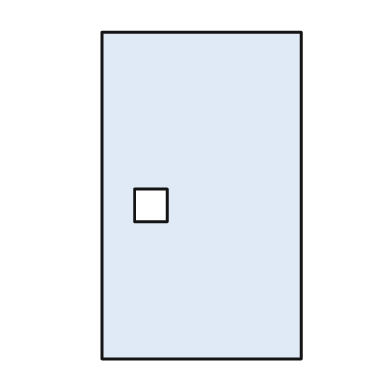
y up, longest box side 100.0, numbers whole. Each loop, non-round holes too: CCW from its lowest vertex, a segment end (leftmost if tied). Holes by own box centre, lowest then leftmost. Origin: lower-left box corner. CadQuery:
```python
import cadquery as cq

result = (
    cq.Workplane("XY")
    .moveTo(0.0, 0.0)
    .lineTo(61.0, 0.0)
    .lineTo(61.0, 100.0)
    .lineTo(0.0, 100.0)
    .close()
    .moveTo(10.0, 42.0)
    .lineTo(20.0, 42.0)
    .lineTo(20.0, 52.0)
    .lineTo(10.0, 52.0)
    .close()
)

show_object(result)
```